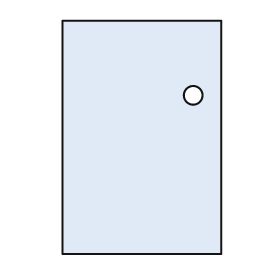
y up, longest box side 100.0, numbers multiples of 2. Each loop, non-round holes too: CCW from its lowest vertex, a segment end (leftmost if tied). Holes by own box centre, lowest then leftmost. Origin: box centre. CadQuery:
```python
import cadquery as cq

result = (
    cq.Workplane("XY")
    .moveTo(-34.0, -50.0)
    .lineTo(34.0, -50.0)
    .lineTo(34.0, 50.0)
    .lineTo(-34.0, 50.0)
    .close()
    .moveTo(22.0, 18.0)
    .circle(4.0)
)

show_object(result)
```